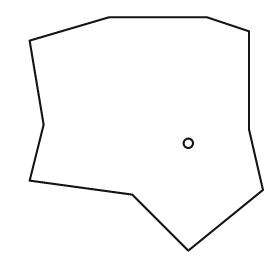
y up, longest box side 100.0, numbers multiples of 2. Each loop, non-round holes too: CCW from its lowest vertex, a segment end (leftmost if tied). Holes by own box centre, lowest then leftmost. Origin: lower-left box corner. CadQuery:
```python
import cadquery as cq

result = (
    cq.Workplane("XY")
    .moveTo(68.0, 0.0)
    .lineTo(100.0, 26.0)
    .lineTo(94.0, 52.0)
    .lineTo(94.0, 94.0)
    .lineTo(76.0, 100.0)
    .lineTo(34.0, 100.0)
    .lineTo(0.0, 90.0)
    .lineTo(6.0, 54.0)
    .lineTo(0.0, 30.0)
    .lineTo(44.0, 24.0)
    .close()
    .moveTo(68.0, 46.0)
    .circle(2.0)
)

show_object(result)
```